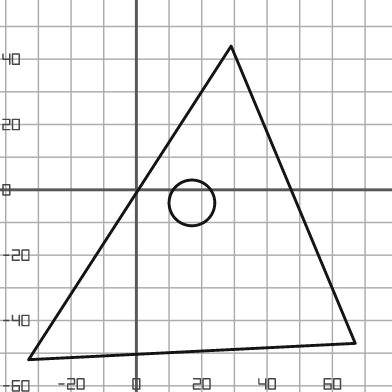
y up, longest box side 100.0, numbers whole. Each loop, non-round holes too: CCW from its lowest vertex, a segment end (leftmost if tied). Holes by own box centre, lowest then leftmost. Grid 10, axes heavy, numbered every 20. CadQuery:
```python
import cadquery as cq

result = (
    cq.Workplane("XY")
    .moveTo(-33.0, -52.0)
    .lineTo(67.0, -47.0)
    .lineTo(29.0, 44.0)
    .close()
    .moveTo(17.0, -4.0)
    .circle(7.0)
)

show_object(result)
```